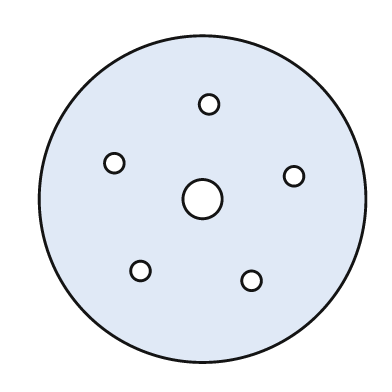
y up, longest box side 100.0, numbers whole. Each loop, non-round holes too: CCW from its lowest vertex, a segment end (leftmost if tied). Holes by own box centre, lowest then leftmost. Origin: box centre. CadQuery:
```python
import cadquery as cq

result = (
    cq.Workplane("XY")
    .moveTo(0.0, 0.0)
    .circle(50.0)
    .moveTo(15.0, -25.0)
    .circle(3.0)
    .moveTo(-19.0, -22.0)
    .circle(3.0)
    .moveTo(0.0, 0.0)
    .circle(6.0)
    .moveTo(28.0, 7.0)
    .circle(3.0)
    .moveTo(-27.0, 11.0)
    .circle(3.0)
    .moveTo(2.0, 29.0)
    .circle(3.0)
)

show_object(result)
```